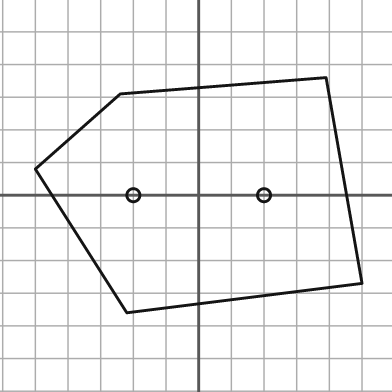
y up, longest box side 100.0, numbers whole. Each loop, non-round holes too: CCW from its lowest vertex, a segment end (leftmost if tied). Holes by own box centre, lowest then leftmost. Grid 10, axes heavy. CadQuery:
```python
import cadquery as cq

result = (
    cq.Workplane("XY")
    .moveTo(-22.0, -36.0)
    .lineTo(50.0, -27.0)
    .lineTo(39.0, 36.0)
    .lineTo(-24.0, 31.0)
    .lineTo(-50.0, 8.0)
    .close()
    .moveTo(-20.0, 0.0)
    .circle(2.0)
    .moveTo(20.0, 0.0)
    .circle(2.0)
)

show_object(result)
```